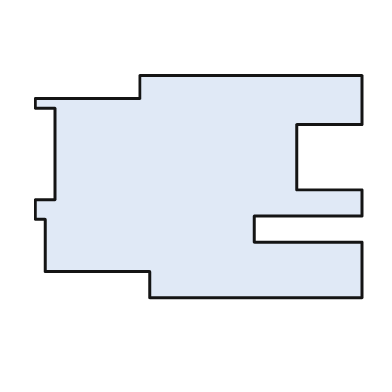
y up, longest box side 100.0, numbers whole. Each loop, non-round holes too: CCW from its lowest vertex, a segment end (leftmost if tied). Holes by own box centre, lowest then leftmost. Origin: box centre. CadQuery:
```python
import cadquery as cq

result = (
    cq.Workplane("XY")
    .moveTo(-15.0, -34.0)
    .lineTo(50.0, -34.0)
    .lineTo(50.0, -17.0)
    .lineTo(17.0, -17.0)
    .lineTo(17.0, -9.0)
    .lineTo(50.0, -9.0)
    .lineTo(50.0, -1.0)
    .lineTo(30.0, -1.0)
    .lineTo(30.0, 19.0)
    .lineTo(50.0, 19.0)
    .lineTo(50.0, 34.0)
    .lineTo(-18.0, 34.0)
    .lineTo(-18.0, 27.0)
    .lineTo(-50.0, 27.0)
    .lineTo(-50.0, 24.0)
    .lineTo(-44.0, 24.0)
    .lineTo(-44.0, -4.0)
    .lineTo(-50.0, -4.0)
    .lineTo(-50.0, -10.0)
    .lineTo(-47.0, -10.0)
    .lineTo(-47.0, -26.0)
    .lineTo(-15.0, -26.0)
    .close()
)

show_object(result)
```